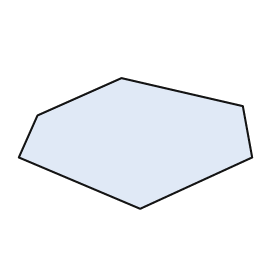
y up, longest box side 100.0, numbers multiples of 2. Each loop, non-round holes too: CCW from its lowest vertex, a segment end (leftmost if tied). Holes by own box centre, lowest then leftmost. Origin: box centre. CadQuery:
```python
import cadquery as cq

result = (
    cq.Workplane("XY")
    .moveTo(2.0, -28.0)
    .lineTo(50.0, -6.0)
    .lineTo(46.0, 16.0)
    .lineTo(-6.0, 28.0)
    .lineTo(-42.0, 12.0)
    .lineTo(-50.0, -6.0)
    .close()
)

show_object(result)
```